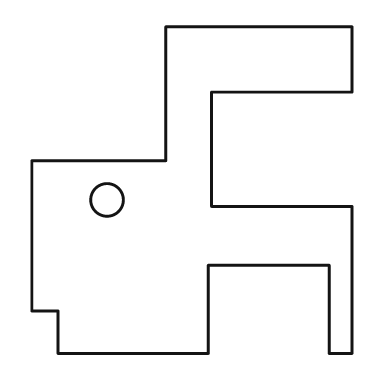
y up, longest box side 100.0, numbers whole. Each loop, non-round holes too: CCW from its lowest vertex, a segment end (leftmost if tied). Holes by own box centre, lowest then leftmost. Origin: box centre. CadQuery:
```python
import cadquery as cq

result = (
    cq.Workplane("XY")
    .moveTo(-41.0, -50.0)
    .lineTo(5.0, -50.0)
    .lineTo(5.0, -23.0)
    .lineTo(42.0, -23.0)
    .lineTo(42.0, -50.0)
    .lineTo(49.0, -50.0)
    .lineTo(49.0, -5.0)
    .lineTo(6.0, -5.0)
    .lineTo(6.0, 30.0)
    .lineTo(49.0, 30.0)
    .lineTo(49.0, 50.0)
    .lineTo(-8.0, 50.0)
    .lineTo(-8.0, 9.0)
    .lineTo(-49.0, 9.0)
    .lineTo(-49.0, -37.0)
    .lineTo(-41.0, -37.0)
    .close()
    .moveTo(-26.0, -3.0)
    .circle(5.0)
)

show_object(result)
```